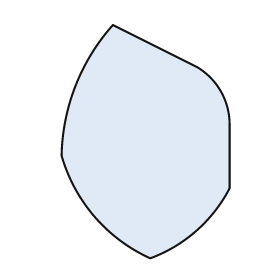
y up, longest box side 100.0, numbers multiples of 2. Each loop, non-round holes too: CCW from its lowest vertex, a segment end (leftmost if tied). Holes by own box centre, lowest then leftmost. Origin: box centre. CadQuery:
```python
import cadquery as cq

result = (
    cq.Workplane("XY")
    .moveTo(2.0, -50.0)
    .threePointArc((22.0, -38.0), (36.0, -20.0))
    .lineTo(36.0, 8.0)
    .threePointArc((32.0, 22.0), (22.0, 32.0))
    .lineTo(-14.0, 50.0)
    .threePointArc((-30.0, 24.0), (-36.0, -6.0))
    .threePointArc((-22.0, -32.0), (2.0, -50.0))
    .close()
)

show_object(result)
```